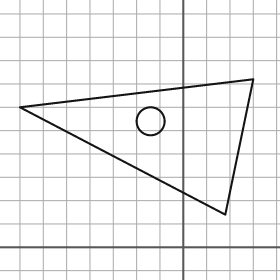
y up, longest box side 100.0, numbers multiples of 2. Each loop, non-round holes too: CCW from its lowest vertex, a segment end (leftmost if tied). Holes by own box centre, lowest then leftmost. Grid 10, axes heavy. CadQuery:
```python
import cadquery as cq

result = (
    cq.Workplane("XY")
    .moveTo(18.0, 14.0)
    .lineTo(30.0, 72.0)
    .lineTo(-70.0, 60.0)
    .close()
    .moveTo(-14.0, 54.0)
    .circle(6.0)
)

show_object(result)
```